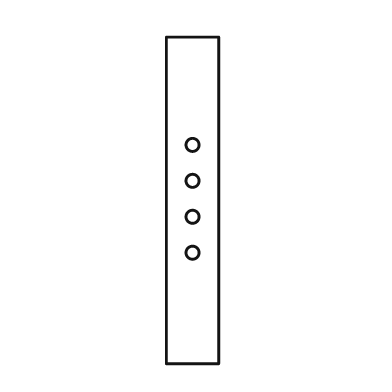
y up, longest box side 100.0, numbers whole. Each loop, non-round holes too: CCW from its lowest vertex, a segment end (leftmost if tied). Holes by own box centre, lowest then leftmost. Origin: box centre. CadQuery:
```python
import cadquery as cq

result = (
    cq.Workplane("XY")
    .moveTo(-8.0, -50.0)
    .lineTo(8.0, -50.0)
    .lineTo(8.0, 50.0)
    .lineTo(-8.0, 50.0)
    .close()
    .moveTo(0.0, -16.0)
    .circle(2.0)
    .moveTo(0.0, -5.0)
    .circle(2.0)
    .moveTo(0.0, 6.0)
    .circle(2.0)
    .moveTo(0.0, 17.0)
    .circle(2.0)
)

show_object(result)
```